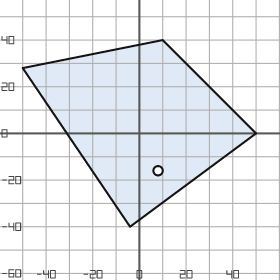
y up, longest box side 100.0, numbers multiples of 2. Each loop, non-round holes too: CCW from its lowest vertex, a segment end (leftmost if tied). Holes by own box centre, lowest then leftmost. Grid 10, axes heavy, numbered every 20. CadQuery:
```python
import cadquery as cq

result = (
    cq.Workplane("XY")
    .moveTo(-4.0, -40.0)
    .lineTo(50.0, 0.0)
    .lineTo(10.0, 40.0)
    .lineTo(-50.0, 28.0)
    .close()
    .moveTo(8.0, -16.0)
    .circle(2.0)
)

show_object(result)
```